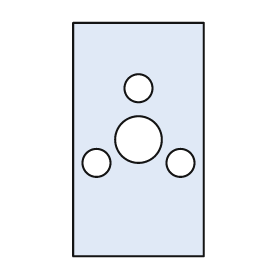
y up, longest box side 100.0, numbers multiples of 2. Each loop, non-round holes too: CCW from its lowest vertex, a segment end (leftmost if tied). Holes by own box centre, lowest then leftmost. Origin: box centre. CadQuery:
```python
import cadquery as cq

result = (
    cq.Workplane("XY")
    .moveTo(-28.0, -50.0)
    .lineTo(28.0, -50.0)
    .lineTo(28.0, 50.0)
    .lineTo(-28.0, 50.0)
    .close()
    .moveTo(-18.0, -10.0)
    .circle(6.0)
    .moveTo(18.0, -10.0)
    .circle(6.0)
    .moveTo(0.0, 0.0)
    .circle(10.0)
    .moveTo(0.0, 22.0)
    .circle(6.0)
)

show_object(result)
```